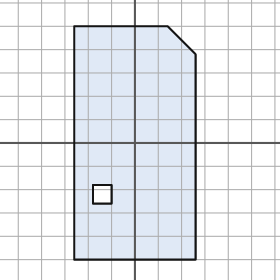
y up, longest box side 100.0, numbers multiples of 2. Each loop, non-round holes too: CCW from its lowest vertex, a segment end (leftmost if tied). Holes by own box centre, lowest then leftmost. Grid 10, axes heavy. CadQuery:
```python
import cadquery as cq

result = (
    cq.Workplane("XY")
    .moveTo(-26.0, -50.0)
    .lineTo(26.0, -50.0)
    .lineTo(26.0, 38.0)
    .lineTo(14.0, 50.0)
    .lineTo(-26.0, 50.0)
    .close()
    .moveTo(-18.0, -26.0)
    .lineTo(-10.0, -26.0)
    .lineTo(-10.0, -18.0)
    .lineTo(-18.0, -18.0)
    .close()
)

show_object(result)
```